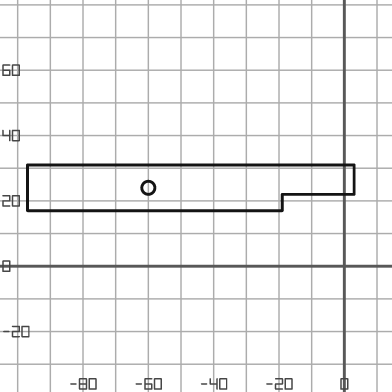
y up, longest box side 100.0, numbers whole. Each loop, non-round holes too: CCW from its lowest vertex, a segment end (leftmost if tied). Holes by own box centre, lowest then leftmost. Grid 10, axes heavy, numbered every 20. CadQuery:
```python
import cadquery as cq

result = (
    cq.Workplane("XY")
    .moveTo(-97.0, 17.0)
    .lineTo(-19.0, 17.0)
    .lineTo(-19.0, 22.0)
    .lineTo(3.0, 22.0)
    .lineTo(3.0, 31.0)
    .lineTo(-97.0, 31.0)
    .close()
    .moveTo(-60.0, 24.0)
    .circle(2.0)
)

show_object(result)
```